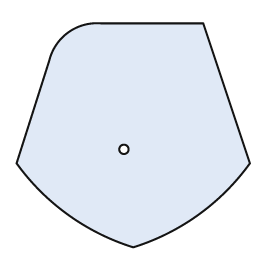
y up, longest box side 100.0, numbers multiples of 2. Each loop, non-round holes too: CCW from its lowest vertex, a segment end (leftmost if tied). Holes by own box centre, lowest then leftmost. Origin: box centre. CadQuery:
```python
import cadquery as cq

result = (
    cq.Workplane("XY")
    .moveTo(0.0, -48.0)
    .threePointArc((28.0, -34.0), (50.0, -12.0))
    .lineTo(30.0, 48.0)
    .lineTo(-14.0, 48.0)
    .threePointArc((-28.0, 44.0), (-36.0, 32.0))
    .lineTo(-50.0, -12.0)
    .threePointArc((-28.0, -34.0), (0.0, -48.0))
    .close()
    .moveTo(-4.0, -6.0)
    .circle(2.0)
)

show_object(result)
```